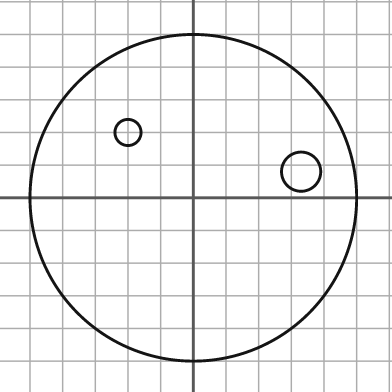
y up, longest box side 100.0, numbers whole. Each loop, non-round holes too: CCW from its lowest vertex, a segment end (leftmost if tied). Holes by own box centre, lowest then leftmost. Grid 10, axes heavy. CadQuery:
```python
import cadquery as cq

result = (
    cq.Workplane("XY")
    .moveTo(0.0, 0.0)
    .circle(50.0)
    .moveTo(33.0, 8.0)
    .circle(6.0)
    .moveTo(-20.0, 20.0)
    .circle(4.0)
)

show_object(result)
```